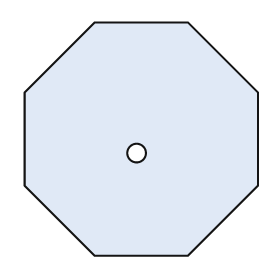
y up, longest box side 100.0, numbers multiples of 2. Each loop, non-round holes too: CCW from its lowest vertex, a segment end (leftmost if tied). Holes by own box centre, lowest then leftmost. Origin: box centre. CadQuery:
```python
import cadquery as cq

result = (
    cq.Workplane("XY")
    .moveTo(-20.0, -50.0)
    .lineTo(20.0, -50.0)
    .lineTo(50.0, -20.0)
    .lineTo(50.0, 20.0)
    .lineTo(20.0, 50.0)
    .lineTo(-20.0, 50.0)
    .lineTo(-50.0, 20.0)
    .lineTo(-50.0, -20.0)
    .close()
    .moveTo(-2.0, -6.0)
    .circle(4.0)
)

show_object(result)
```